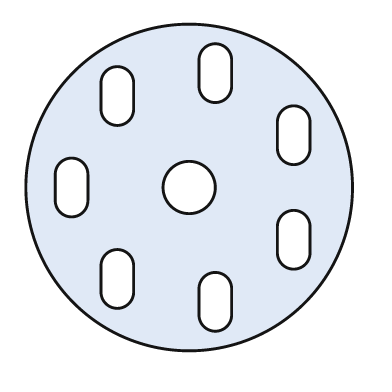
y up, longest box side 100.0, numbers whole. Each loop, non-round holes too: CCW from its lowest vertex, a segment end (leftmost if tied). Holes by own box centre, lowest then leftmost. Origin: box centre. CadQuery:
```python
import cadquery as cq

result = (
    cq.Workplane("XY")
    .moveTo(0.0, 0.0)
    .circle(50.0)
    .moveTo(3.0, -39.0)
    .threePointArc((8.0, -44.0), (13.0, -39.0))
    .lineTo(13.0, -31.0)
    .threePointArc((8.0, -26.0), (3.0, -31.0))
    .close()
    .moveTo(-27.0, -32.0)
    .threePointArc((-22.0, -37.0), (-17.0, -32.0))
    .lineTo(-17.0, -24.0)
    .threePointArc((-22.0, -19.0), (-27.0, -24.0))
    .close()
    .moveTo(27.0, -20.0)
    .threePointArc((32.0, -25.0), (37.0, -20.0))
    .lineTo(37.0, -12.0)
    .threePointArc((32.0, -7.0), (27.0, -12.0))
    .close()
    .moveTo(-41.0, -4.0)
    .threePointArc((-36.0, -9.0), (-31.0, -4.0))
    .lineTo(-31.0, 4.0)
    .threePointArc((-36.0, 9.0), (-41.0, 4.0))
    .close()
    .moveTo(0.0, 0.0)
    .circle(8.0)
    .moveTo(27.0, 12.0)
    .threePointArc((32.0, 7.0), (37.0, 12.0))
    .lineTo(37.0, 20.0)
    .threePointArc((32.0, 25.0), (27.0, 20.0))
    .close()
    .moveTo(-27.0, 24.0)
    .threePointArc((-22.0, 19.0), (-17.0, 24.0))
    .lineTo(-17.0, 32.0)
    .threePointArc((-22.0, 37.0), (-27.0, 32.0))
    .close()
    .moveTo(3.0, 31.0)
    .threePointArc((8.0, 26.0), (13.0, 31.0))
    .lineTo(13.0, 39.0)
    .threePointArc((8.0, 44.0), (3.0, 39.0))
    .close()
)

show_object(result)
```